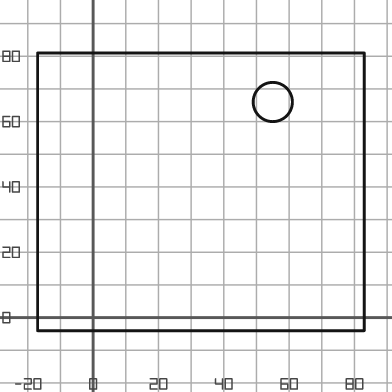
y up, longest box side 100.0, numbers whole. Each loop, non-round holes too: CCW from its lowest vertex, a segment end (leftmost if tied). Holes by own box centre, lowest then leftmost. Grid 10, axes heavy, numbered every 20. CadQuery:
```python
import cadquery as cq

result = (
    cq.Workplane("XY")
    .moveTo(-17.0, -4.0)
    .lineTo(83.0, -4.0)
    .lineTo(83.0, 81.0)
    .lineTo(-17.0, 81.0)
    .close()
    .moveTo(55.0, 66.0)
    .circle(6.0)
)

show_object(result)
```